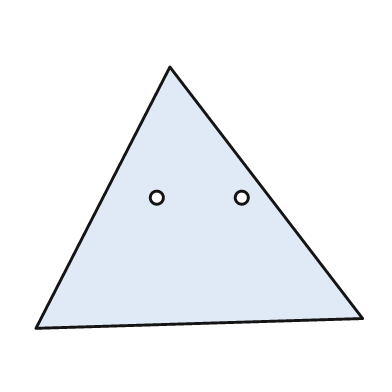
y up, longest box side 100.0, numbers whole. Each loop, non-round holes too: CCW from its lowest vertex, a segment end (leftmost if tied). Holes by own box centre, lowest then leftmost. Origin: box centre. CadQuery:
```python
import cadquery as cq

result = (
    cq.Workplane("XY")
    .moveTo(-50.0, -40.0)
    .lineTo(50.0, -37.0)
    .lineTo(-9.0, 40.0)
    .close()
    .moveTo(-13.0, 0.0)
    .circle(2.0)
    .moveTo(13.0, 0.0)
    .circle(2.0)
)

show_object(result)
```